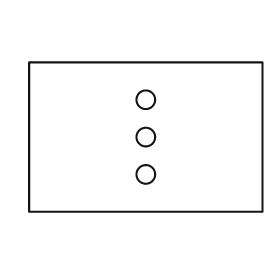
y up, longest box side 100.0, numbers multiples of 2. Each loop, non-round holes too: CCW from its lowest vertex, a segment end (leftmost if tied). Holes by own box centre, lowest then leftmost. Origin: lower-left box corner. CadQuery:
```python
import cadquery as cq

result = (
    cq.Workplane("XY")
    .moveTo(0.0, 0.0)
    .lineTo(100.0, 0.0)
    .lineTo(100.0, 64.0)
    .lineTo(0.0, 64.0)
    .close()
    .moveTo(50.0, 16.0)
    .circle(4.0)
    .moveTo(50.0, 32.0)
    .circle(4.0)
    .moveTo(50.0, 48.0)
    .circle(4.0)
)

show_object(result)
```